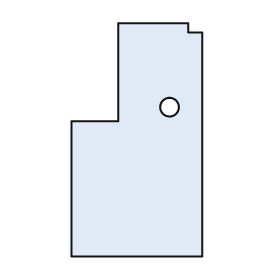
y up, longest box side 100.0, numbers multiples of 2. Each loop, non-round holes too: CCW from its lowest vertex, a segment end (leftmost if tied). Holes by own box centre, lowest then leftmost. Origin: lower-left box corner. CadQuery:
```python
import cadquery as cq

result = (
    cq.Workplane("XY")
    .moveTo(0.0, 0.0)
    .lineTo(56.0, 0.0)
    .lineTo(56.0, 96.0)
    .lineTo(50.0, 96.0)
    .lineTo(50.0, 100.0)
    .lineTo(20.0, 100.0)
    .lineTo(20.0, 58.0)
    .lineTo(0.0, 58.0)
    .close()
    .moveTo(42.0, 64.0)
    .circle(4.0)
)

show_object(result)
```